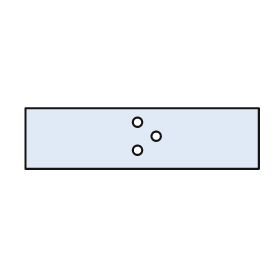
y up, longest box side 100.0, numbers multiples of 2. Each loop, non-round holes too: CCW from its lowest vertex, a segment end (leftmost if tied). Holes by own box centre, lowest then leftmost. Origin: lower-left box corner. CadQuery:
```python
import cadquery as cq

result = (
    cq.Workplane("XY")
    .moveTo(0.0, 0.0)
    .lineTo(100.0, 0.0)
    .lineTo(100.0, 26.0)
    .lineTo(0.0, 26.0)
    .close()
    .moveTo(48.0, 8.0)
    .circle(2.0)
    .moveTo(56.0, 14.0)
    .circle(2.0)
    .moveTo(48.0, 20.0)
    .circle(2.0)
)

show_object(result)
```